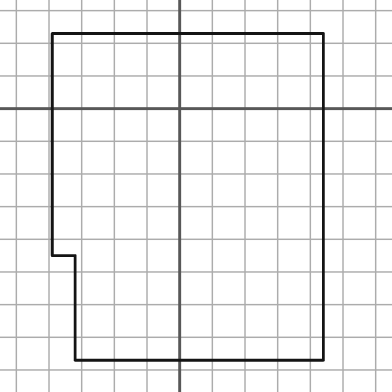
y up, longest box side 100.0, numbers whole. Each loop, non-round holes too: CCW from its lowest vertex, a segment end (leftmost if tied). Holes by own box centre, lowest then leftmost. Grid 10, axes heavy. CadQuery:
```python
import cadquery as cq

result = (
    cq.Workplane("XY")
    .moveTo(-32.0, -77.0)
    .lineTo(44.0, -77.0)
    .lineTo(44.0, 23.0)
    .lineTo(-39.0, 23.0)
    .lineTo(-39.0, -45.0)
    .lineTo(-32.0, -45.0)
    .close()
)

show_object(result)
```